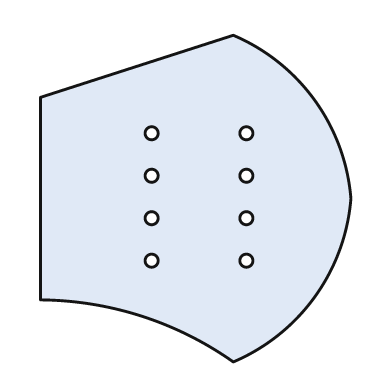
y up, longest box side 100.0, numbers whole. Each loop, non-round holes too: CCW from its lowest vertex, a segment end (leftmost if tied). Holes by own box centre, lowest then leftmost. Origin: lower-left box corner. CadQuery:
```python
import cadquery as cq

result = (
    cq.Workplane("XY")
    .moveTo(59.0, 0.0)
    .threePointArc((84.0, 20.0), (95.0, 50.0))
    .threePointArc((84.0, 80.0), (59.0, 100.0))
    .lineTo(0.0, 81.0)
    .lineTo(0.0, 19.0)
    .threePointArc((31.0, 14.0), (59.0, 0.0))
    .close()
    .moveTo(34.0, 31.0)
    .circle(2.0)
    .moveTo(63.0, 31.0)
    .circle(2.0)
    .moveTo(34.0, 44.0)
    .circle(2.0)
    .moveTo(63.0, 44.0)
    .circle(2.0)
    .moveTo(34.0, 57.0)
    .circle(2.0)
    .moveTo(63.0, 57.0)
    .circle(2.0)
    .moveTo(34.0, 70.0)
    .circle(2.0)
    .moveTo(63.0, 70.0)
    .circle(2.0)
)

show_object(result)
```